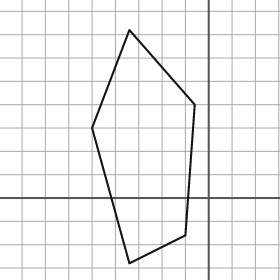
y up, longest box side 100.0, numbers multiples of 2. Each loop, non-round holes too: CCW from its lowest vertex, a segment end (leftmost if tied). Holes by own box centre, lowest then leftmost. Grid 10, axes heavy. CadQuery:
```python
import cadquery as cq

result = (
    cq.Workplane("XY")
    .moveTo(-34.0, -28.0)
    .lineTo(-10.0, -16.0)
    .lineTo(-6.0, 40.0)
    .lineTo(-34.0, 72.0)
    .lineTo(-50.0, 30.0)
    .close()
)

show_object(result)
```